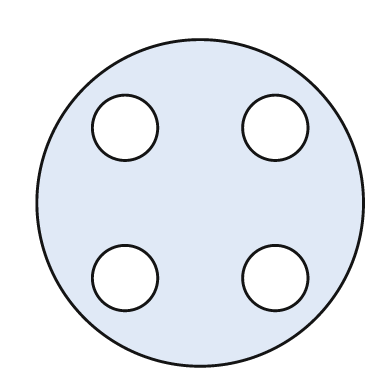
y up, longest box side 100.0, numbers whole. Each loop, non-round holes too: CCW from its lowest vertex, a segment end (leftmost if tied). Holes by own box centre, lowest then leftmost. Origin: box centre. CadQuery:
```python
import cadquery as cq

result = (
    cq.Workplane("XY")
    .moveTo(0.0, 0.0)
    .circle(50.0)
    .moveTo(-23.0, -23.0)
    .circle(10.0)
    .moveTo(23.0, -23.0)
    .circle(10.0)
    .moveTo(-23.0, 23.0)
    .circle(10.0)
    .moveTo(23.0, 23.0)
    .circle(10.0)
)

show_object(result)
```